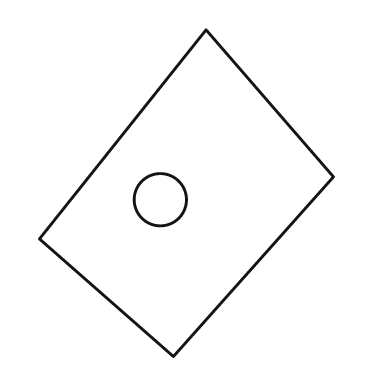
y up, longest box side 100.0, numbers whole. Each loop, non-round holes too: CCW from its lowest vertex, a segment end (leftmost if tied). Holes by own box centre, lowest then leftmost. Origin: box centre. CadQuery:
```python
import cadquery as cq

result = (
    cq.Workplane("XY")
    .moveTo(-4.0, -50.0)
    .lineTo(45.0, 5.0)
    .lineTo(6.0, 50.0)
    .lineTo(-45.0, -14.0)
    .close()
    .moveTo(-8.0, -2.0)
    .circle(8.0)
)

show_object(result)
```